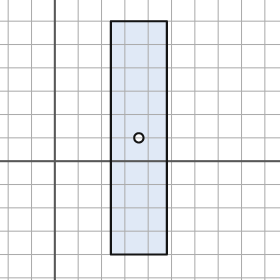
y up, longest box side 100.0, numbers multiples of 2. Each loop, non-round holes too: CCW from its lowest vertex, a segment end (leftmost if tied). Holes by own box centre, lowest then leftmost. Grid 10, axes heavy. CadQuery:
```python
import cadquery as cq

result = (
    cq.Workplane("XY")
    .moveTo(24.0, -40.0)
    .lineTo(48.0, -40.0)
    .lineTo(48.0, 60.0)
    .lineTo(24.0, 60.0)
    .close()
    .moveTo(36.0, 10.0)
    .circle(2.0)
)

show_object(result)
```